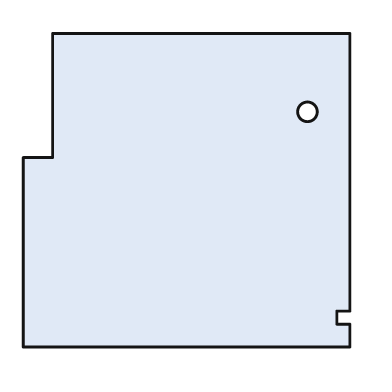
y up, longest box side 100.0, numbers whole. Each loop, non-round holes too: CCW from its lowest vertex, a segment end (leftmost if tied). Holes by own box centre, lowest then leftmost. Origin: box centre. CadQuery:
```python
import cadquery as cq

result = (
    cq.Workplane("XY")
    .moveTo(-50.0, -48.0)
    .lineTo(50.0, -48.0)
    .lineTo(50.0, -41.0)
    .lineTo(46.0, -41.0)
    .lineTo(46.0, -37.0)
    .lineTo(50.0, -37.0)
    .lineTo(50.0, 48.0)
    .lineTo(-41.0, 48.0)
    .lineTo(-41.0, 10.0)
    .lineTo(-50.0, 10.0)
    .close()
    .moveTo(37.0, 24.0)
    .circle(3.0)
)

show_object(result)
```